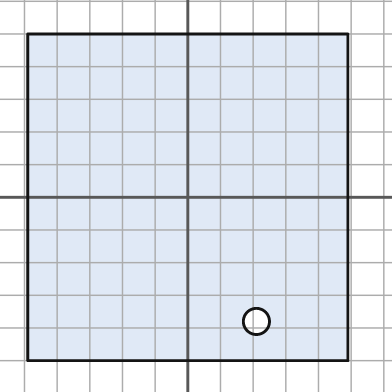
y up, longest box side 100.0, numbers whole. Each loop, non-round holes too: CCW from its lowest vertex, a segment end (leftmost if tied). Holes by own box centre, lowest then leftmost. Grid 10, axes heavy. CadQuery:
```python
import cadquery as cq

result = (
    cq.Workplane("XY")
    .moveTo(-49.0, -50.0)
    .lineTo(49.0, -50.0)
    .lineTo(49.0, 50.0)
    .lineTo(-49.0, 50.0)
    .close()
    .moveTo(21.0, -38.0)
    .circle(4.0)
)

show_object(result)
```